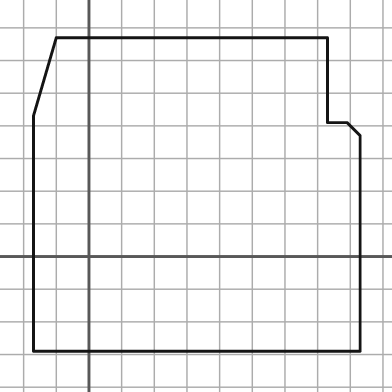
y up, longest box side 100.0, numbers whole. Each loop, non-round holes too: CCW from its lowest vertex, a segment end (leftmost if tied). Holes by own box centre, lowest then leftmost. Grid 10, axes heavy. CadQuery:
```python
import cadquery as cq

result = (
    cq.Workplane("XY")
    .moveTo(-17.0, -29.0)
    .lineTo(83.0, -29.0)
    .lineTo(83.0, 37.0)
    .lineTo(79.0, 41.0)
    .lineTo(73.0, 41.0)
    .lineTo(73.0, 67.0)
    .lineTo(-10.0, 67.0)
    .lineTo(-17.0, 43.0)
    .close()
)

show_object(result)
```